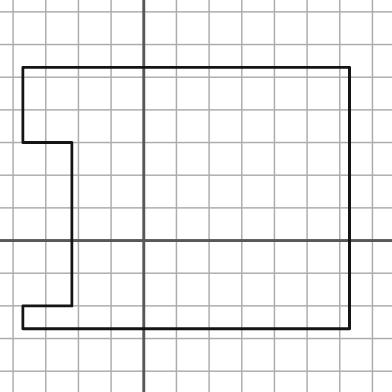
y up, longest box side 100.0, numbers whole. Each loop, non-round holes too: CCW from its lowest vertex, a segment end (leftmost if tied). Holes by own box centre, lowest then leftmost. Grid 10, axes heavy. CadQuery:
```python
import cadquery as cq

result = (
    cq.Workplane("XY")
    .moveTo(-37.0, -27.0)
    .lineTo(63.0, -27.0)
    .lineTo(63.0, 53.0)
    .lineTo(-37.0, 53.0)
    .lineTo(-37.0, 30.0)
    .lineTo(-22.0, 30.0)
    .lineTo(-22.0, -20.0)
    .lineTo(-37.0, -20.0)
    .close()
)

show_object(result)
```